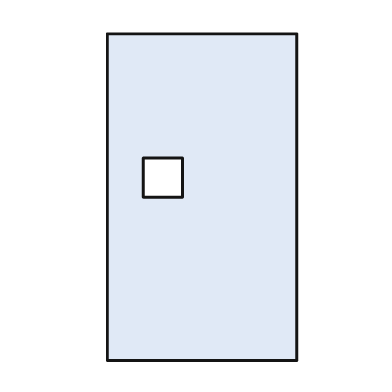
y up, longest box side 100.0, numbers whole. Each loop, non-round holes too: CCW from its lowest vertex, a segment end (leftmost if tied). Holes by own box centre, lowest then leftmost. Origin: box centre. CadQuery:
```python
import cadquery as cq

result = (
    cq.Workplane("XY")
    .moveTo(-29.0, -50.0)
    .lineTo(29.0, -50.0)
    .lineTo(29.0, 50.0)
    .lineTo(-29.0, 50.0)
    .close()
    .moveTo(-18.0, 0.0)
    .lineTo(-6.0, 0.0)
    .lineTo(-6.0, 12.0)
    .lineTo(-18.0, 12.0)
    .close()
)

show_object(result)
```